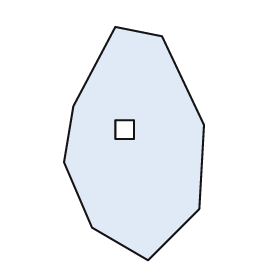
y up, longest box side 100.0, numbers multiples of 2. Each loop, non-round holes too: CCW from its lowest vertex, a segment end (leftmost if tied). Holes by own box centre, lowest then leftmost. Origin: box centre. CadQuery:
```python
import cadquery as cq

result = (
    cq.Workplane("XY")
    .moveTo(6.0, -50.0)
    .lineTo(28.0, -28.0)
    .lineTo(30.0, 8.0)
    .lineTo(12.0, 46.0)
    .lineTo(-8.0, 50.0)
    .lineTo(-26.0, 16.0)
    .lineTo(-30.0, -8.0)
    .lineTo(-18.0, -36.0)
    .close()
    .moveTo(-8.0, 2.0)
    .lineTo(0.0, 2.0)
    .lineTo(0.0, 10.0)
    .lineTo(-8.0, 10.0)
    .close()
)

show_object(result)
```